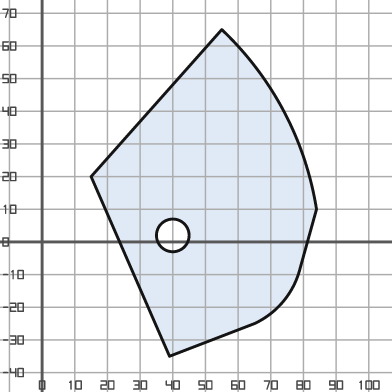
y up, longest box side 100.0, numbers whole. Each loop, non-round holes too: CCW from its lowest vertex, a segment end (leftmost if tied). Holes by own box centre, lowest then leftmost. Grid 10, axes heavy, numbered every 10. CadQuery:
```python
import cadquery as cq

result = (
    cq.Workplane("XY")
    .moveTo(39.0, -35.0)
    .lineTo(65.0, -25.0)
    .threePointArc((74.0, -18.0), (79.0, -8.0))
    .lineTo(84.0, 10.0)
    .threePointArc((74.0, 40.0), (55.0, 65.0))
    .lineTo(15.0, 20.0)
    .close()
    .moveTo(40.0, 2.0)
    .circle(5.0)
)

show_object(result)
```